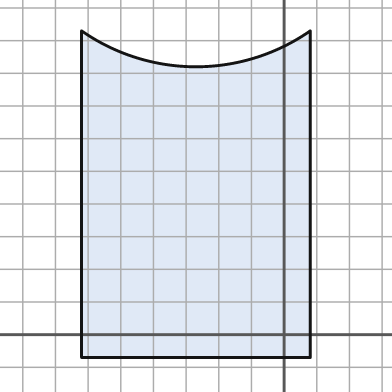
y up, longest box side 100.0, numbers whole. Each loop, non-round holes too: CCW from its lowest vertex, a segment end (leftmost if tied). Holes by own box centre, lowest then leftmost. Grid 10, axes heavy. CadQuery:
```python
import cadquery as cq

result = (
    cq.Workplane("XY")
    .moveTo(-62.0, -7.0)
    .lineTo(8.0, -7.0)
    .lineTo(8.0, 93.0)
    .threePointArc((-27.0, 82.0), (-62.0, 93.0))
    .close()
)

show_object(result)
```